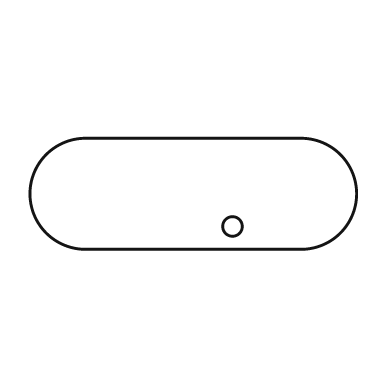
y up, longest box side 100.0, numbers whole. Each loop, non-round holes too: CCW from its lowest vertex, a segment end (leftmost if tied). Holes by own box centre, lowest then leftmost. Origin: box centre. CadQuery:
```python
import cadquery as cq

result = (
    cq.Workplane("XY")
    .moveTo(-33.0, -17.0)
    .lineTo(33.0, -17.0)
    .threePointArc((50.0, 0.0), (33.0, 17.0))
    .lineTo(-33.0, 17.0)
    .threePointArc((-50.0, 0.0), (-33.0, -17.0))
    .close()
    .moveTo(12.0, -10.0)
    .circle(3.0)
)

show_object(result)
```